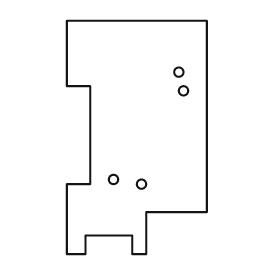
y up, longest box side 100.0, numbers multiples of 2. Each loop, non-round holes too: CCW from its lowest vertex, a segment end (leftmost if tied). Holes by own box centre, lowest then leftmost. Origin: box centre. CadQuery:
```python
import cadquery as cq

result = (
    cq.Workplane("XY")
    .moveTo(-30.0, -50.0)
    .lineTo(-22.0, -50.0)
    .lineTo(-22.0, -42.0)
    .lineTo(-2.0, -42.0)
    .lineTo(-2.0, -50.0)
    .lineTo(4.0, -50.0)
    .lineTo(4.0, -32.0)
    .lineTo(30.0, -32.0)
    .lineTo(30.0, 50.0)
    .lineTo(-30.0, 50.0)
    .lineTo(-30.0, 22.0)
    .lineTo(-20.0, 22.0)
    .lineTo(-20.0, -20.0)
    .lineTo(-30.0, -20.0)
    .close()
    .moveTo(2.0, -20.0)
    .circle(2.0)
    .moveTo(-10.0, -18.0)
    .circle(2.0)
    .moveTo(20.0, 20.0)
    .circle(2.0)
    .moveTo(18.0, 28.0)
    .circle(2.0)
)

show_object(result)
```